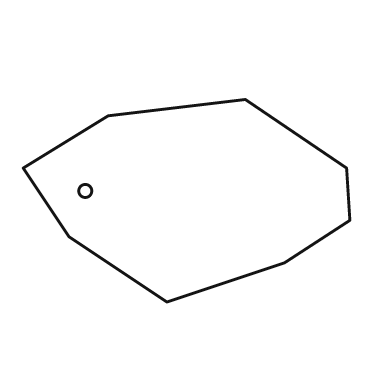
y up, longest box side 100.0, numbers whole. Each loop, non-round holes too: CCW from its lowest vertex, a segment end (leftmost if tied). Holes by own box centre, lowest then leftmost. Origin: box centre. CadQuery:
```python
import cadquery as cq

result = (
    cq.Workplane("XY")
    .moveTo(-6.0, -31.0)
    .lineTo(30.0, -19.0)
    .lineTo(50.0, -6.0)
    .lineTo(49.0, 10.0)
    .lineTo(18.0, 31.0)
    .lineTo(-24.0, 26.0)
    .lineTo(-50.0, 10.0)
    .lineTo(-36.0, -11.0)
    .close()
    .moveTo(-31.0, 3.0)
    .circle(2.0)
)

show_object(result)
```